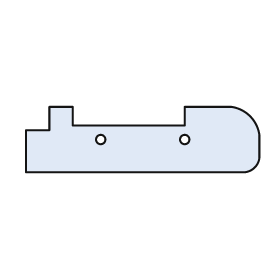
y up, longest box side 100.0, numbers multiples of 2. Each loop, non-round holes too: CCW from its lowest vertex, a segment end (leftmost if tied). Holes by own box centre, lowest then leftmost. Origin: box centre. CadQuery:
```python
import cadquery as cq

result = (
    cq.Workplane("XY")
    .moveTo(-50.0, -14.0)
    .lineTo(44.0, -14.0)
    .threePointArc((48.0, -12.0), (50.0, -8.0))
    .lineTo(50.0, 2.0)
    .threePointArc((46.0, 10.0), (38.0, 14.0))
    .lineTo(18.0, 14.0)
    .lineTo(18.0, 6.0)
    .lineTo(-30.0, 6.0)
    .lineTo(-30.0, 14.0)
    .lineTo(-40.0, 14.0)
    .lineTo(-40.0, 4.0)
    .lineTo(-50.0, 4.0)
    .close()
    .moveTo(-18.0, 0.0)
    .circle(2.0)
    .moveTo(18.0, 0.0)
    .circle(2.0)
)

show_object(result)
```